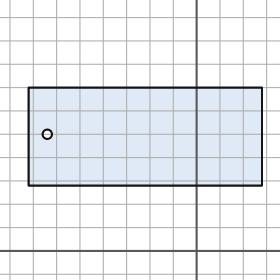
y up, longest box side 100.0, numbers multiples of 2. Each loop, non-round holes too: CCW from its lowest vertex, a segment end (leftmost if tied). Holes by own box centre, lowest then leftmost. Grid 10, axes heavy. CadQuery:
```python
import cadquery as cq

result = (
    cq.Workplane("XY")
    .moveTo(-72.0, 28.0)
    .lineTo(28.0, 28.0)
    .lineTo(28.0, 70.0)
    .lineTo(-72.0, 70.0)
    .close()
    .moveTo(-64.0, 50.0)
    .circle(2.0)
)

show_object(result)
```